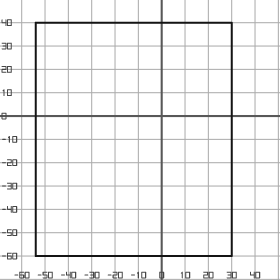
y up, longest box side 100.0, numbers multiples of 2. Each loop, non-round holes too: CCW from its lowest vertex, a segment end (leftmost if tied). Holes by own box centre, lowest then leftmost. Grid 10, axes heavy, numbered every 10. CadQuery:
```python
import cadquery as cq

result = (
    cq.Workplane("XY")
    .moveTo(-54.0, -60.0)
    .lineTo(30.0, -60.0)
    .lineTo(30.0, 40.0)
    .lineTo(-54.0, 40.0)
    .close()
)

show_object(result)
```